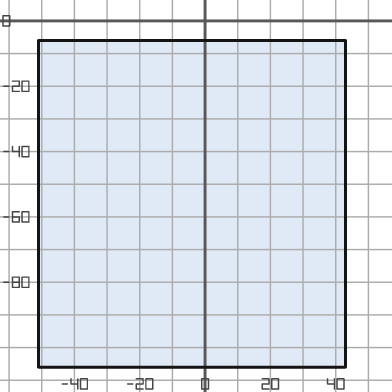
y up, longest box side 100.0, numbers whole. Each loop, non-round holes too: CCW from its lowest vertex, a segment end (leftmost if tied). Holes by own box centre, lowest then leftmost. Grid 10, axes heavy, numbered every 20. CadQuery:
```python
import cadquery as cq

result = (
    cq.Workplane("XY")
    .moveTo(-51.0, -106.0)
    .lineTo(43.0, -106.0)
    .lineTo(43.0, -6.0)
    .lineTo(-51.0, -6.0)
    .close()
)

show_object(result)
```